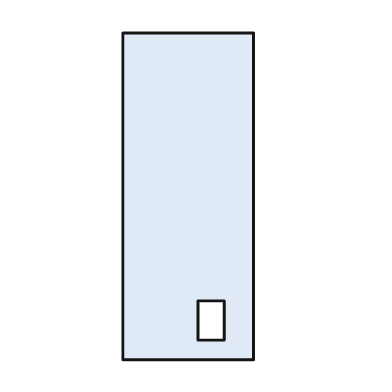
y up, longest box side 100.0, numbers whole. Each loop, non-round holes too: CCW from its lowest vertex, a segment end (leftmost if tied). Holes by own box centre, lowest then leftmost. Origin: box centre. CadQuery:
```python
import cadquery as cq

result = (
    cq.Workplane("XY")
    .moveTo(-20.0, -50.0)
    .lineTo(20.0, -50.0)
    .lineTo(20.0, 50.0)
    .lineTo(-20.0, 50.0)
    .close()
    .moveTo(3.0, -44.0)
    .lineTo(11.0, -44.0)
    .lineTo(11.0, -32.0)
    .lineTo(3.0, -32.0)
    .close()
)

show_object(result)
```